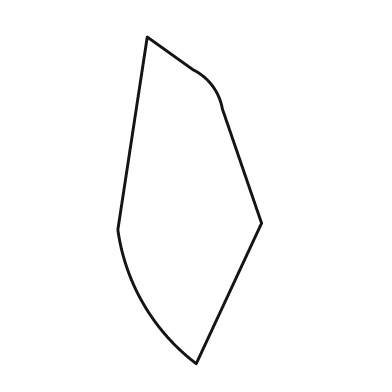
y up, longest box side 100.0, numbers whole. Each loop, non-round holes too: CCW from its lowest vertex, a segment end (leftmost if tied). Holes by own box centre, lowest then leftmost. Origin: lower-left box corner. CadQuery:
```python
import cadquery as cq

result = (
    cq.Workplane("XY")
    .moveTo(24.0, 0.0)
    .lineTo(44.0, 43.0)
    .lineTo(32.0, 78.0)
    .threePointArc((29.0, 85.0), (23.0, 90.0))
    .lineTo(9.0, 100.0)
    .lineTo(0.0, 41.0)
    .threePointArc((8.0, 18.0), (24.0, 0.0))
    .close()
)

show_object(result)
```